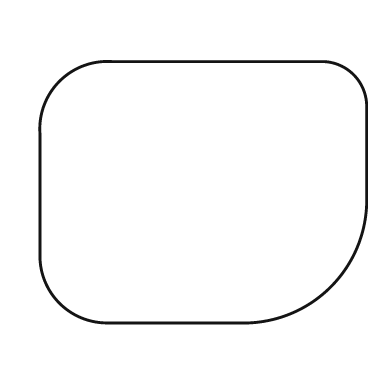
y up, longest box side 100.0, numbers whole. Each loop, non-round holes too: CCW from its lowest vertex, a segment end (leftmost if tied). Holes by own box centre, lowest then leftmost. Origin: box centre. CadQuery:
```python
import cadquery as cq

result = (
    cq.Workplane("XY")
    .moveTo(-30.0, -40.0)
    .lineTo(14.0, -40.0)
    .threePointArc((39.0, -29.0), (50.0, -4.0))
    .lineTo(50.0, 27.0)
    .threePointArc((46.0, 36.0), (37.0, 40.0))
    .lineTo(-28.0, 40.0)
    .threePointArc((-44.0, 34.0), (-50.0, 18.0))
    .lineTo(-50.0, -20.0)
    .threePointArc((-44.0, -34.0), (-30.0, -40.0))
    .close()
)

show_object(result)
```